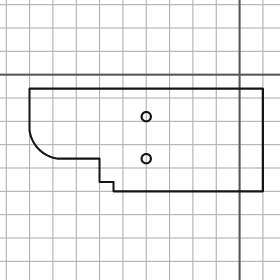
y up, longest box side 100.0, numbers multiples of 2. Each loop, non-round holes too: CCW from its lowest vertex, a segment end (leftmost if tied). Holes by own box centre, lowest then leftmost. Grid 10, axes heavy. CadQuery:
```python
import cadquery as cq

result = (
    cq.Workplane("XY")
    .moveTo(-54.0, -50.0)
    .lineTo(10.0, -50.0)
    .lineTo(10.0, -6.0)
    .lineTo(-90.0, -6.0)
    .lineTo(-90.0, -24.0)
    .threePointArc((-86.0, -32.0), (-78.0, -36.0))
    .lineTo(-60.0, -36.0)
    .lineTo(-60.0, -46.0)
    .lineTo(-54.0, -46.0)
    .close()
    .moveTo(-40.0, -36.0)
    .circle(2.0)
    .moveTo(-40.0, -18.0)
    .circle(2.0)
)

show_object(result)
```